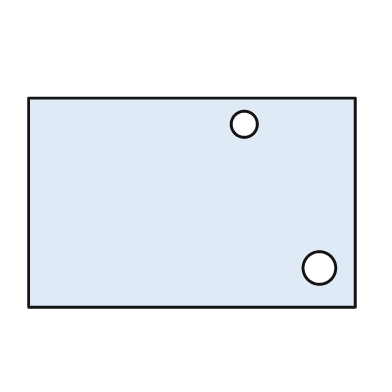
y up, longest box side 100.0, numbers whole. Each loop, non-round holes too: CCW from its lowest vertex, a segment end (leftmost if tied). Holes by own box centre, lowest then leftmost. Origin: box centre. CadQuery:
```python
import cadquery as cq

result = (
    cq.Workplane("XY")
    .moveTo(-50.0, -32.0)
    .lineTo(50.0, -32.0)
    .lineTo(50.0, 32.0)
    .lineTo(-50.0, 32.0)
    .close()
    .moveTo(39.0, -20.0)
    .circle(5.0)
    .moveTo(16.0, 24.0)
    .circle(4.0)
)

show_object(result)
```